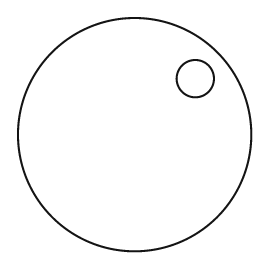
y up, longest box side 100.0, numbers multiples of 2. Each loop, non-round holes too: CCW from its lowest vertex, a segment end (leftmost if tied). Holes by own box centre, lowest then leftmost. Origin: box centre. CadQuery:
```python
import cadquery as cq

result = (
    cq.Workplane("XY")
    .moveTo(0.0, 0.0)
    .circle(50.0)
    .moveTo(26.0, 24.0)
    .circle(8.0)
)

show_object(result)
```